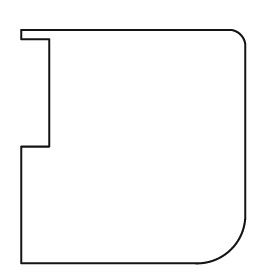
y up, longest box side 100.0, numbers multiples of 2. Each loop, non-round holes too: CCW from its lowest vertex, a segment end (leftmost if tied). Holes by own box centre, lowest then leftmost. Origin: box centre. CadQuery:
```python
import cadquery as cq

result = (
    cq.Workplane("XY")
    .moveTo(-48.0, -50.0)
    .lineTo(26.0, -50.0)
    .threePointArc((42.0, -44.0), (48.0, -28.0))
    .lineTo(48.0, 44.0)
    .threePointArc((46.0, 48.0), (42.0, 50.0))
    .lineTo(-48.0, 50.0)
    .lineTo(-48.0, 46.0)
    .lineTo(-36.0, 46.0)
    .lineTo(-36.0, 0.0)
    .lineTo(-48.0, 0.0)
    .close()
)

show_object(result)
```